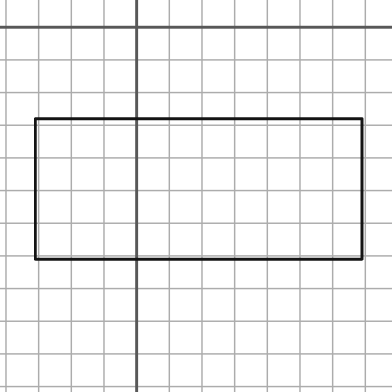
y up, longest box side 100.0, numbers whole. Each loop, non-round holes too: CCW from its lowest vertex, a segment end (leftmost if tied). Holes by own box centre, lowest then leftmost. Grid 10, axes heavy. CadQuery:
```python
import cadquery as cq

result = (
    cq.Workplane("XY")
    .moveTo(-31.0, -71.0)
    .lineTo(69.0, -71.0)
    .lineTo(69.0, -28.0)
    .lineTo(-31.0, -28.0)
    .close()
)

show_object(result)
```